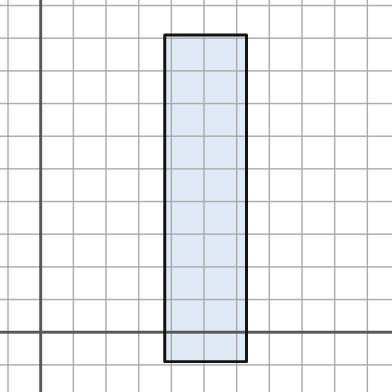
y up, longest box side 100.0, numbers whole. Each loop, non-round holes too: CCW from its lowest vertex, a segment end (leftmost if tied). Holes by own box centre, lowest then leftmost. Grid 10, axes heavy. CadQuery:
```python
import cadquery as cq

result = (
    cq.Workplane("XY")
    .moveTo(38.0, -9.0)
    .lineTo(63.0, -9.0)
    .lineTo(63.0, 91.0)
    .lineTo(38.0, 91.0)
    .close()
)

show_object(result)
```